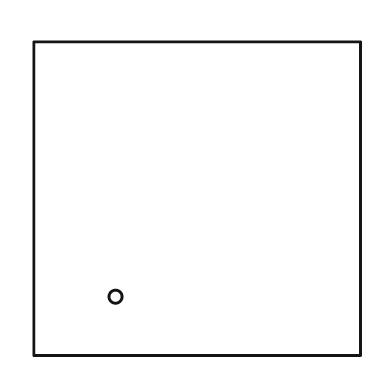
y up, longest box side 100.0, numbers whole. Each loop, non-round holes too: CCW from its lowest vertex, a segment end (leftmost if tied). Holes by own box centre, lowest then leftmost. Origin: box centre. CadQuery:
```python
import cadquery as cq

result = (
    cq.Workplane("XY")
    .moveTo(-50.0, -48.0)
    .lineTo(50.0, -48.0)
    .lineTo(50.0, 48.0)
    .lineTo(-50.0, 48.0)
    .close()
    .moveTo(-25.0, -30.0)
    .circle(2.0)
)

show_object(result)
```